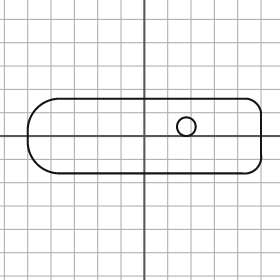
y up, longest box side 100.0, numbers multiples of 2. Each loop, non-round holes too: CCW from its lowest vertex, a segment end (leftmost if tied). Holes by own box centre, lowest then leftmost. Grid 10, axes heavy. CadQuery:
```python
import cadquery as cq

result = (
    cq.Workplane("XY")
    .moveTo(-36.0, -16.0)
    .lineTo(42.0, -16.0)
    .threePointArc((48.0, -14.0), (50.0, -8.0))
    .lineTo(50.0, 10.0)
    .threePointArc((48.0, 14.0), (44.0, 16.0))
    .lineTo(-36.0, 16.0)
    .threePointArc((-46.0, 12.0), (-50.0, 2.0))
    .lineTo(-50.0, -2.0)
    .threePointArc((-46.0, -12.0), (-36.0, -16.0))
    .close()
    .moveTo(18.0, 4.0)
    .circle(4.0)
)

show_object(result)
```